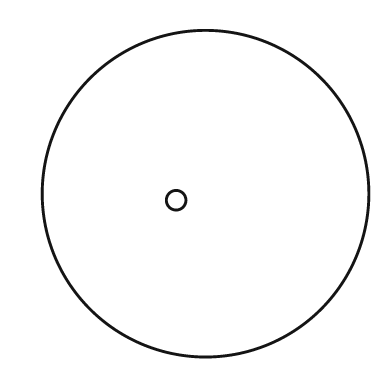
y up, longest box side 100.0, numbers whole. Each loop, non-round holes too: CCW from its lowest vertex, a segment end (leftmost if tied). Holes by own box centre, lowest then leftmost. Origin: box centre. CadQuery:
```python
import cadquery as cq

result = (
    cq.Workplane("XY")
    .moveTo(0.0, 0.0)
    .circle(50.0)
    .moveTo(-9.0, -2.0)
    .circle(3.0)
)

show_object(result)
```